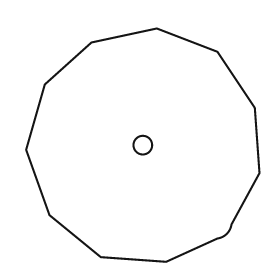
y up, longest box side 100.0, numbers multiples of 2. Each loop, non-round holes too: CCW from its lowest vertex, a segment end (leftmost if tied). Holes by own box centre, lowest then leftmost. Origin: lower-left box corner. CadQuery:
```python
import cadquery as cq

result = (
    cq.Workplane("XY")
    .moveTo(60.0, 0.0)
    .lineTo(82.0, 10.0)
    .threePointArc((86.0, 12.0), (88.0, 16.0))
    .lineTo(100.0, 38.0)
    .lineTo(98.0, 66.0)
    .lineTo(82.0, 90.0)
    .lineTo(56.0, 100.0)
    .lineTo(28.0, 94.0)
    .lineTo(8.0, 76.0)
    .lineTo(0.0, 48.0)
    .lineTo(10.0, 20.0)
    .lineTo(32.0, 2.0)
    .close()
    .moveTo(50.0, 50.0)
    .circle(4.0)
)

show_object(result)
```